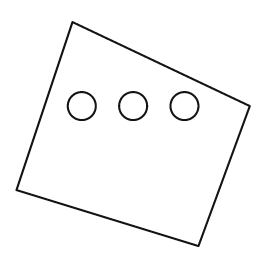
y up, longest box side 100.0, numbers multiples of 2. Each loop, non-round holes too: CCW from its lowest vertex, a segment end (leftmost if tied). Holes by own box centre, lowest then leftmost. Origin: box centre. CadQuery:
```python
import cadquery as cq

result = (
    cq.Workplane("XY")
    .moveTo(28.0, -48.0)
    .lineTo(50.0, 12.0)
    .lineTo(-26.0, 48.0)
    .lineTo(-50.0, -24.0)
    .close()
    .moveTo(-22.0, 12.0)
    .circle(6.0)
    .moveTo(0.0, 12.0)
    .circle(6.0)
    .moveTo(22.0, 12.0)
    .circle(6.0)
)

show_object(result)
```